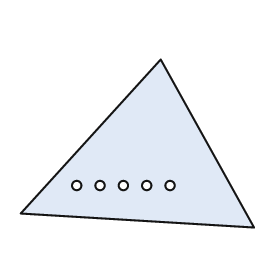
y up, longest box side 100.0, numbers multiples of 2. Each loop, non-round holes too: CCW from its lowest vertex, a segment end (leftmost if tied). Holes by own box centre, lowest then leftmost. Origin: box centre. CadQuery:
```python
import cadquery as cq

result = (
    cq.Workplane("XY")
    .moveTo(50.0, -36.0)
    .lineTo(10.0, 36.0)
    .lineTo(-50.0, -30.0)
    .close()
    .moveTo(-26.0, -18.0)
    .circle(2.0)
    .moveTo(-16.0, -18.0)
    .circle(2.0)
    .moveTo(-6.0, -18.0)
    .circle(2.0)
    .moveTo(4.0, -18.0)
    .circle(2.0)
    .moveTo(14.0, -18.0)
    .circle(2.0)
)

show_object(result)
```